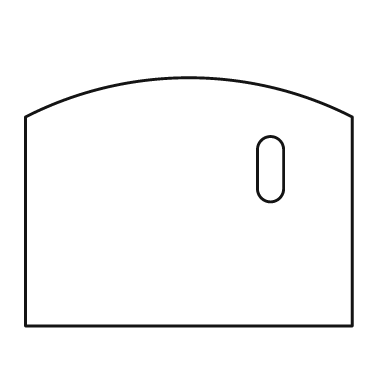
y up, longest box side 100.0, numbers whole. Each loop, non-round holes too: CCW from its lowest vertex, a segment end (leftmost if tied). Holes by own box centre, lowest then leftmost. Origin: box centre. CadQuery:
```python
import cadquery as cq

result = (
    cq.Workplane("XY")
    .moveTo(-50.0, -38.0)
    .lineTo(50.0, -38.0)
    .lineTo(50.0, 26.0)
    .threePointArc((0.0, 38.0), (-50.0, 26.0))
    .close()
    .moveTo(21.0, 4.0)
    .threePointArc((25.0, 0.0), (29.0, 4.0))
    .lineTo(29.0, 16.0)
    .threePointArc((25.0, 20.0), (21.0, 16.0))
    .close()
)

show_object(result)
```